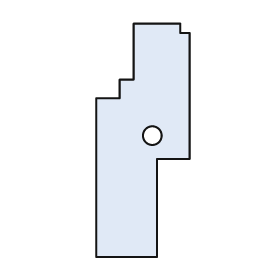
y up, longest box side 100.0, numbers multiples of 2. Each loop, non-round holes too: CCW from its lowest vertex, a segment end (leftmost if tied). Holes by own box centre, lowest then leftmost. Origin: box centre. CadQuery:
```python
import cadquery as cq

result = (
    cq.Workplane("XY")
    .moveTo(-20.0, -50.0)
    .lineTo(6.0, -50.0)
    .lineTo(6.0, -8.0)
    .lineTo(20.0, -8.0)
    .lineTo(20.0, 46.0)
    .lineTo(16.0, 46.0)
    .lineTo(16.0, 50.0)
    .lineTo(-4.0, 50.0)
    .lineTo(-4.0, 26.0)
    .lineTo(-10.0, 26.0)
    .lineTo(-10.0, 18.0)
    .lineTo(-20.0, 18.0)
    .close()
    .moveTo(4.0, 2.0)
    .circle(4.0)
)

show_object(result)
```